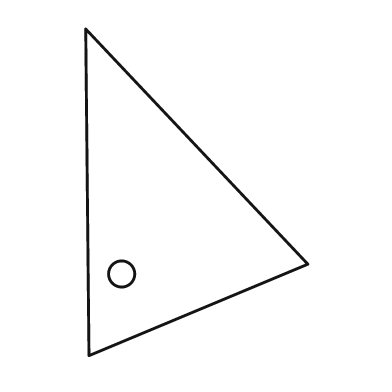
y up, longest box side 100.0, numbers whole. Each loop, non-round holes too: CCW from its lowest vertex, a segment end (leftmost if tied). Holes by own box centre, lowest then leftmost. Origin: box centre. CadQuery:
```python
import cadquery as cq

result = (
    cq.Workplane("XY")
    .moveTo(-33.0, -50.0)
    .lineTo(34.0, -22.0)
    .lineTo(-34.0, 50.0)
    .close()
    .moveTo(-23.0, -25.0)
    .circle(4.0)
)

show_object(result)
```